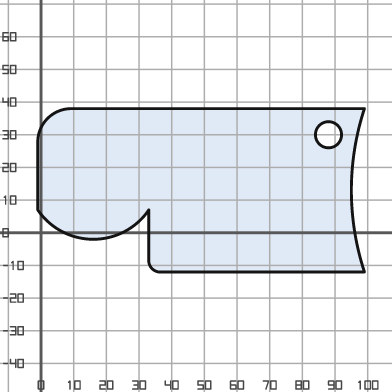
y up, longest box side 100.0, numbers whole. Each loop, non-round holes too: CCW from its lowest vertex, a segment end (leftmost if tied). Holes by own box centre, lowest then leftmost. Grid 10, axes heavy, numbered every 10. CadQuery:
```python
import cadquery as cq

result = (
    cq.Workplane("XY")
    .moveTo(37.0, -12.0)
    .lineTo(99.0, -12.0)
    .threePointArc((95.0, 13.0), (99.0, 38.0))
    .lineTo(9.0, 38.0)
    .threePointArc((2.0, 35.0), (-1.0, 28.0))
    .lineTo(-1.0, 7.0)
    .threePointArc((16.0, -2.0), (33.0, 7.0))
    .lineTo(33.0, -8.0)
    .threePointArc((34.0, -11.0), (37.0, -12.0))
    .close()
    .moveTo(88.0, 30.0)
    .circle(4.0)
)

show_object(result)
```